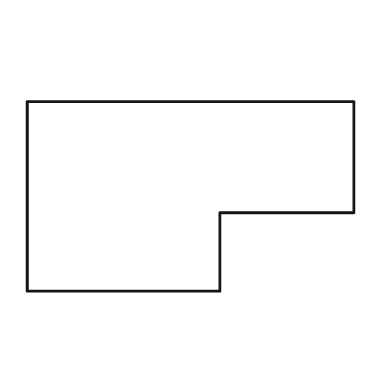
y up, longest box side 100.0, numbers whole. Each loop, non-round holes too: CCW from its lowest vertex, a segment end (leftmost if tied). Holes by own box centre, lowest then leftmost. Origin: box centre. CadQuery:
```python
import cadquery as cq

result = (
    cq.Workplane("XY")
    .moveTo(-50.0, -29.0)
    .lineTo(9.0, -29.0)
    .lineTo(9.0, -5.0)
    .lineTo(50.0, -5.0)
    .lineTo(50.0, 29.0)
    .lineTo(-50.0, 29.0)
    .close()
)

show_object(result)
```